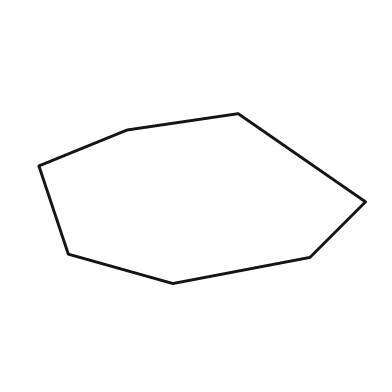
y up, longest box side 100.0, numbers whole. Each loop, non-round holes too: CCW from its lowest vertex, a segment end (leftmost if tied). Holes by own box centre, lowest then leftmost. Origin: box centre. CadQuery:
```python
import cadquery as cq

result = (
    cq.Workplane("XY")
    .moveTo(-9.0, -26.0)
    .lineTo(33.0, -18.0)
    .lineTo(50.0, -1.0)
    .lineTo(11.0, 26.0)
    .lineTo(-23.0, 21.0)
    .lineTo(-50.0, 10.0)
    .lineTo(-41.0, -17.0)
    .close()
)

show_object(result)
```